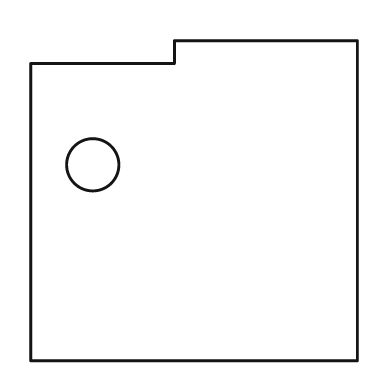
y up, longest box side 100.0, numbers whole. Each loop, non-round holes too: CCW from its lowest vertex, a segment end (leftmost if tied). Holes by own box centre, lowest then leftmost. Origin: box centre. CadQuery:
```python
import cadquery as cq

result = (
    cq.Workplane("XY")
    .moveTo(-50.0, -49.0)
    .lineTo(50.0, -49.0)
    .lineTo(50.0, 49.0)
    .lineTo(-6.0, 49.0)
    .lineTo(-6.0, 42.0)
    .lineTo(-50.0, 42.0)
    .close()
    .moveTo(-31.0, 11.0)
    .circle(8.0)
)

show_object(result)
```